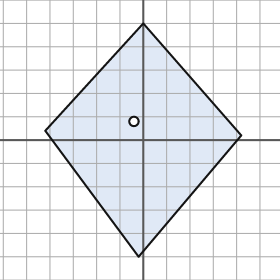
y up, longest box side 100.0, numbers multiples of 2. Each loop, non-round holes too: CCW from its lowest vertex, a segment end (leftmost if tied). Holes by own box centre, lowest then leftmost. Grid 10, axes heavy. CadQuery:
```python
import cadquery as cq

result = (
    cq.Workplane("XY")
    .moveTo(-2.0, -50.0)
    .lineTo(42.0, 2.0)
    .lineTo(0.0, 50.0)
    .lineTo(-42.0, 4.0)
    .close()
    .moveTo(-4.0, 8.0)
    .circle(2.0)
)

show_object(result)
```